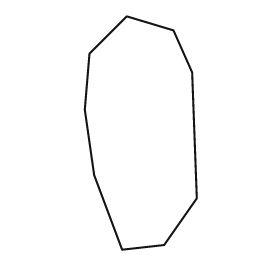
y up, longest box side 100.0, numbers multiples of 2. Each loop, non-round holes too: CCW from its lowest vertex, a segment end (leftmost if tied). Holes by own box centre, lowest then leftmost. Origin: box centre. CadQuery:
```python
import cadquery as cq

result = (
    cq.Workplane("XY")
    .moveTo(-8.0, -50.0)
    .lineTo(10.0, -48.0)
    .lineTo(24.0, -28.0)
    .lineTo(22.0, 26.0)
    .lineTo(14.0, 44.0)
    .lineTo(-6.0, 50.0)
    .lineTo(-22.0, 34.0)
    .lineTo(-24.0, 10.0)
    .lineTo(-20.0, -18.0)
    .close()
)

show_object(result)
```